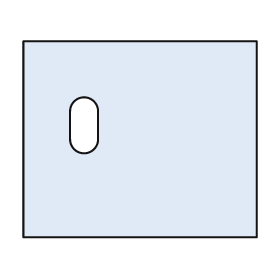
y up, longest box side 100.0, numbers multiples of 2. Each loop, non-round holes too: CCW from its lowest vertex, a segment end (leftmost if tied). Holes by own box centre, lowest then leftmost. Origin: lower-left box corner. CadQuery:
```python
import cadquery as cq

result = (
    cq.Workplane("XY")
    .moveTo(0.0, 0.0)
    .lineTo(100.0, 0.0)
    .lineTo(100.0, 84.0)
    .lineTo(0.0, 84.0)
    .close()
    .moveTo(20.0, 42.0)
    .threePointArc((26.0, 36.0), (32.0, 42.0))
    .lineTo(32.0, 54.0)
    .threePointArc((26.0, 60.0), (20.0, 54.0))
    .close()
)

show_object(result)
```